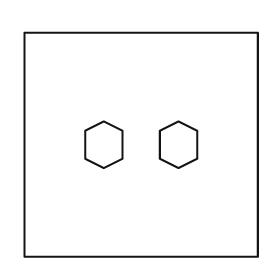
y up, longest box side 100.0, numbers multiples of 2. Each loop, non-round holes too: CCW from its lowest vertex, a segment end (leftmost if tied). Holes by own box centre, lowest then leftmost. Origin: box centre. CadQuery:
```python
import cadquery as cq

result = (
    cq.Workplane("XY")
    .moveTo(-50.0, -48.0)
    .lineTo(50.0, -48.0)
    .lineTo(50.0, 48.0)
    .lineTo(-50.0, 48.0)
    .close()
    .moveTo(-16.0, -10.0)
    .lineTo(-8.0, -6.0)
    .lineTo(-8.0, 6.0)
    .lineTo(-16.0, 10.0)
    .lineTo(-24.0, 6.0)
    .lineTo(-24.0, -6.0)
    .close()
    .moveTo(16.0, -10.0)
    .lineTo(24.0, -6.0)
    .lineTo(24.0, 6.0)
    .lineTo(16.0, 10.0)
    .lineTo(8.0, 6.0)
    .lineTo(8.0, -6.0)
    .close()
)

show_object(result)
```